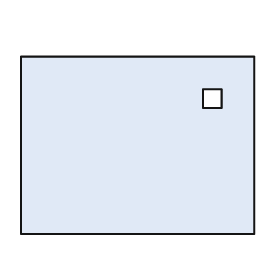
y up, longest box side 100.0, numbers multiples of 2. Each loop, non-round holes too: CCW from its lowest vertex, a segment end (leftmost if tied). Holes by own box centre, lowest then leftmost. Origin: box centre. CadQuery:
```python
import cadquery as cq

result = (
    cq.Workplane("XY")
    .moveTo(-50.0, -38.0)
    .lineTo(50.0, -38.0)
    .lineTo(50.0, 38.0)
    .lineTo(-50.0, 38.0)
    .close()
    .moveTo(28.0, 16.0)
    .lineTo(36.0, 16.0)
    .lineTo(36.0, 24.0)
    .lineTo(28.0, 24.0)
    .close()
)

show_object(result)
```